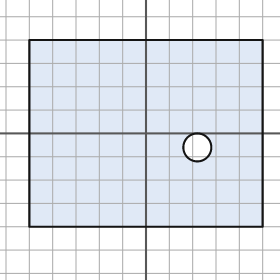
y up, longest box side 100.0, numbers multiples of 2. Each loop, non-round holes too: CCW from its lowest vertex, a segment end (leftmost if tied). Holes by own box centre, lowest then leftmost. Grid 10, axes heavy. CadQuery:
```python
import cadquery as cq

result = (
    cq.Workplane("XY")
    .moveTo(-50.0, -40.0)
    .lineTo(50.0, -40.0)
    .lineTo(50.0, 40.0)
    .lineTo(-50.0, 40.0)
    .close()
    .moveTo(22.0, -6.0)
    .circle(6.0)
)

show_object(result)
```